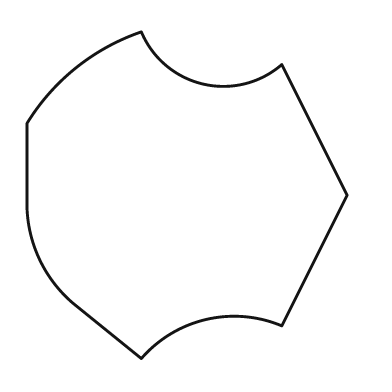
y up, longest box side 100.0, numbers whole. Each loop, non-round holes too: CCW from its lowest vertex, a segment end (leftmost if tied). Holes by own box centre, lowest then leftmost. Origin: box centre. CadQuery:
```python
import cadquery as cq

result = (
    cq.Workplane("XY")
    .moveTo(-14.0, -50.0)
    .threePointArc((6.0, -38.0), (29.0, -40.0))
    .lineTo(49.0, 0.0)
    .lineTo(29.0, 40.0)
    .threePointArc((5.0, 34.0), (-14.0, 50.0))
    .threePointArc((-34.0, 39.0), (-49.0, 22.0))
    .lineTo(-49.0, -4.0)
    .threePointArc((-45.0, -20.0), (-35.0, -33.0))
    .close()
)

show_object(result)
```